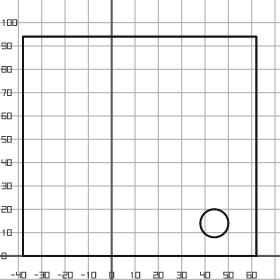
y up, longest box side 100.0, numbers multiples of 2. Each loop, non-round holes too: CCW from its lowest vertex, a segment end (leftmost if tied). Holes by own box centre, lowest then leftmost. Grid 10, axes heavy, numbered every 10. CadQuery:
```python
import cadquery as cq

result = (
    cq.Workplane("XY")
    .moveTo(-38.0, 0.0)
    .lineTo(62.0, 0.0)
    .lineTo(62.0, 94.0)
    .lineTo(-38.0, 94.0)
    .close()
    .moveTo(44.0, 14.0)
    .circle(6.0)
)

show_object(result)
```